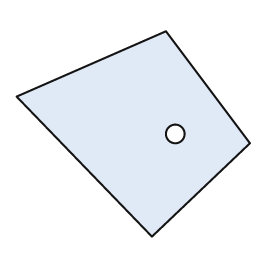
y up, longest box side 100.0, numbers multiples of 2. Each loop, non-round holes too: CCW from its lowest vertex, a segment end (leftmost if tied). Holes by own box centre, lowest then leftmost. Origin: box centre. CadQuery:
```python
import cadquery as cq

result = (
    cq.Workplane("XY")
    .moveTo(8.0, -44.0)
    .lineTo(50.0, -4.0)
    .lineTo(14.0, 44.0)
    .lineTo(-50.0, 16.0)
    .close()
    .moveTo(18.0, 0.0)
    .circle(4.0)
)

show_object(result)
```